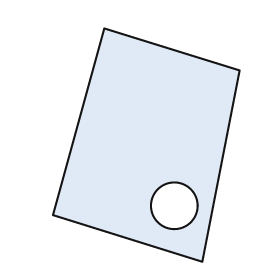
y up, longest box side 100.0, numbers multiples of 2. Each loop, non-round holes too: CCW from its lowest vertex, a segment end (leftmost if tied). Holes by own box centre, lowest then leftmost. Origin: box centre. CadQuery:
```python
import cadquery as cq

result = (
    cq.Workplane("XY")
    .moveTo(24.0, -50.0)
    .lineTo(40.0, 32.0)
    .lineTo(-18.0, 50.0)
    .lineTo(-40.0, -30.0)
    .close()
    .moveTo(12.0, -26.0)
    .circle(10.0)
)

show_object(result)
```